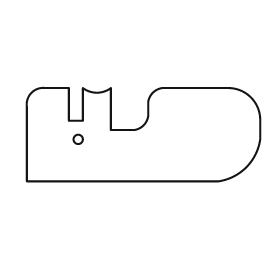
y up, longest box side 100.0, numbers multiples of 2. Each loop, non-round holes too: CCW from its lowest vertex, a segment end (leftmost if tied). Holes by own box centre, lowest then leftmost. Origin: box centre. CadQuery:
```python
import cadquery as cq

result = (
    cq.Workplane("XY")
    .moveTo(-50.0, -20.0)
    .lineTo(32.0, -20.0)
    .threePointArc((44.0, -14.0), (50.0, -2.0))
    .lineTo(50.0, 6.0)
    .threePointArc((46.0, 16.0), (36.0, 20.0))
    .lineTo(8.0, 20.0)
    .threePointArc((4.0, 18.0), (2.0, 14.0))
    .lineTo(2.0, 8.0)
    .threePointArc((0.0, 4.0), (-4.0, 2.0))
    .lineTo(-14.0, 2.0)
    .lineTo(-14.0, 20.0)
    .threePointArc((-20.0, 18.0), (-26.0, 20.0))
    .lineTo(-26.0, 6.0)
    .lineTo(-32.0, 6.0)
    .lineTo(-32.0, 20.0)
    .lineTo(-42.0, 20.0)
    .threePointArc((-48.0, 18.0), (-50.0, 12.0))
    .close()
    .moveTo(-28.0, -2.0)
    .circle(2.0)
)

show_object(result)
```